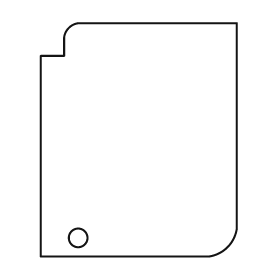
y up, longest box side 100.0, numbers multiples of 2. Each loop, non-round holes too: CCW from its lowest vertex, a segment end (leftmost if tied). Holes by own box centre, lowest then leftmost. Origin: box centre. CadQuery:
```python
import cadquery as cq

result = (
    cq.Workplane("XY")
    .moveTo(-42.0, -50.0)
    .lineTo(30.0, -50.0)
    .threePointArc((38.0, -46.0), (42.0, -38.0))
    .lineTo(42.0, 50.0)
    .lineTo(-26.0, 50.0)
    .threePointArc((-30.0, 48.0), (-32.0, 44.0))
    .lineTo(-32.0, 36.0)
    .lineTo(-42.0, 36.0)
    .close()
    .moveTo(-26.0, -42.0)
    .circle(4.0)
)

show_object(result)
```